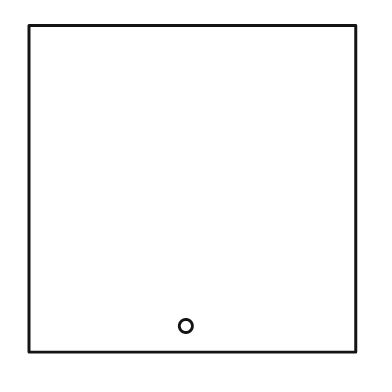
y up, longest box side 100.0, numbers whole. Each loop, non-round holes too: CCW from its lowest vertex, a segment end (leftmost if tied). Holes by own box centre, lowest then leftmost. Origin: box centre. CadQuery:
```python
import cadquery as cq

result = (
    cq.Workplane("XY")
    .moveTo(-50.0, -50.0)
    .lineTo(50.0, -50.0)
    .lineTo(50.0, 50.0)
    .lineTo(-50.0, 50.0)
    .close()
    .moveTo(-2.0, -42.0)
    .circle(2.0)
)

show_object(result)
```